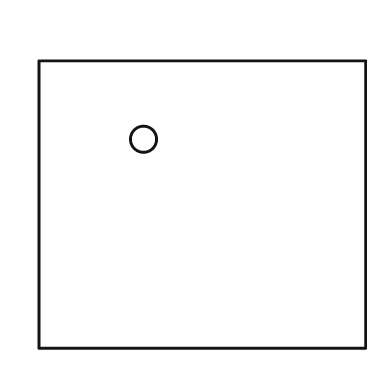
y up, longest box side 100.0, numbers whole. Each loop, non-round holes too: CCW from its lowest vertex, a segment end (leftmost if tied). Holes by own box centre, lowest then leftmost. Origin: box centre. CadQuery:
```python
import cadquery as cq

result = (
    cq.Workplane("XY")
    .moveTo(-50.0, -44.0)
    .lineTo(50.0, -44.0)
    .lineTo(50.0, 44.0)
    .lineTo(-50.0, 44.0)
    .close()
    .moveTo(-18.0, 20.0)
    .circle(4.0)
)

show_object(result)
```